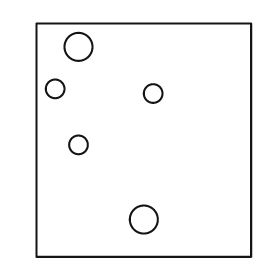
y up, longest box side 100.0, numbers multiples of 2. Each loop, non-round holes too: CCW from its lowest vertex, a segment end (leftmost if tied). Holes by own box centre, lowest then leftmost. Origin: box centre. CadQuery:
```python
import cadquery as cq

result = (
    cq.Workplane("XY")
    .moveTo(-46.0, -50.0)
    .lineTo(46.0, -50.0)
    .lineTo(46.0, 50.0)
    .lineTo(-46.0, 50.0)
    .close()
    .moveTo(0.0, -34.0)
    .circle(6.0)
    .moveTo(-28.0, -2.0)
    .circle(4.0)
    .moveTo(4.0, 20.0)
    .circle(4.0)
    .moveTo(-38.0, 22.0)
    .circle(4.0)
    .moveTo(-28.0, 40.0)
    .circle(6.0)
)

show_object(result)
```